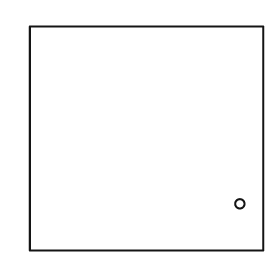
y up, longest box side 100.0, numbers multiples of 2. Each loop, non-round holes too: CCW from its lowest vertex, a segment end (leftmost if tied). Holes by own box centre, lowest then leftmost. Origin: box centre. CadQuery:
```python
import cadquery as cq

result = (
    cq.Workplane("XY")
    .moveTo(-50.0, -48.0)
    .lineTo(50.0, -48.0)
    .lineTo(50.0, 48.0)
    .lineTo(-50.0, 48.0)
    .close()
    .moveTo(40.0, -28.0)
    .circle(2.0)
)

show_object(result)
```